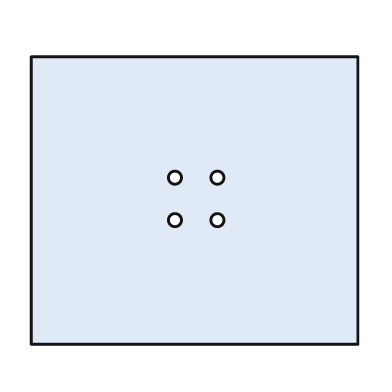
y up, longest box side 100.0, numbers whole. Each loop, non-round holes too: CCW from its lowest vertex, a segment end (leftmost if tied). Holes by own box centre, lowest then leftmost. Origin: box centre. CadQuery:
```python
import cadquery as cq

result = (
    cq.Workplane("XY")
    .moveTo(-50.0, -44.0)
    .lineTo(50.0, -44.0)
    .lineTo(50.0, 44.0)
    .lineTo(-50.0, 44.0)
    .close()
    .moveTo(-6.0, -6.0)
    .circle(2.0)
    .moveTo(7.0, -6.0)
    .circle(2.0)
    .moveTo(-6.0, 7.0)
    .circle(2.0)
    .moveTo(7.0, 7.0)
    .circle(2.0)
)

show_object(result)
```